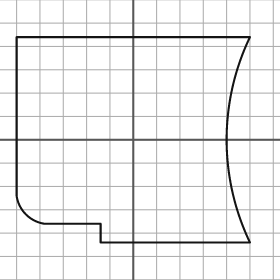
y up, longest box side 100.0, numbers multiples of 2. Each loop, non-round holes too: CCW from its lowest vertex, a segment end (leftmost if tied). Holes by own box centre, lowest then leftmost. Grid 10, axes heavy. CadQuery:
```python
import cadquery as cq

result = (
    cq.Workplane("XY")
    .moveTo(-14.0, -44.0)
    .lineTo(50.0, -44.0)
    .threePointArc((40.0, 0.0), (50.0, 44.0))
    .lineTo(-50.0, 44.0)
    .lineTo(-50.0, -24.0)
    .threePointArc((-46.0, -32.0), (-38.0, -36.0))
    .lineTo(-14.0, -36.0)
    .close()
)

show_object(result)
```